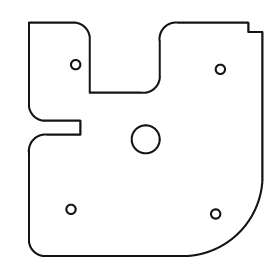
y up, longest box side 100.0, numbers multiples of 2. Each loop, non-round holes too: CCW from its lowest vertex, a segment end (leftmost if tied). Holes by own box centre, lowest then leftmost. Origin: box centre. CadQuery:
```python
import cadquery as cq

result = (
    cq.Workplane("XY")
    .moveTo(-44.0, -50.0)
    .lineTo(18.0, -50.0)
    .threePointArc((40.0, -40.0), (50.0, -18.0))
    .lineTo(50.0, 46.0)
    .lineTo(44.0, 46.0)
    .lineTo(44.0, 50.0)
    .lineTo(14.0, 50.0)
    .threePointArc((8.0, 48.0), (6.0, 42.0))
    .lineTo(6.0, 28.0)
    .threePointArc((4.0, 22.0), (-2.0, 20.0))
    .lineTo(-24.0, 20.0)
    .lineTo(-24.0, 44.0)
    .threePointArc((-26.0, 48.0), (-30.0, 50.0))
    .lineTo(-50.0, 50.0)
    .lineTo(-50.0, 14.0)
    .threePointArc((-48.0, 10.0), (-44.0, 8.0))
    .lineTo(-28.0, 8.0)
    .lineTo(-28.0, 2.0)
    .lineTo(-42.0, 2.0)
    .threePointArc((-48.0, 0.0), (-50.0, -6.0))
    .lineTo(-50.0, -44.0)
    .threePointArc((-48.0, -48.0), (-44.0, -50.0))
    .close()
    .moveTo(30.0, -32.0)
    .circle(2.0)
    .moveTo(-32.0, -30.0)
    .circle(2.0)
    .moveTo(0.0, 0.0)
    .circle(6.0)
    .moveTo(32.0, 30.0)
    .circle(2.0)
    .moveTo(-30.0, 32.0)
    .circle(2.0)
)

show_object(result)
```